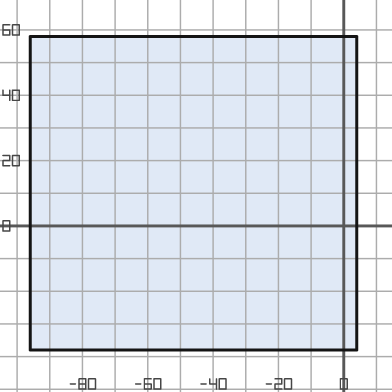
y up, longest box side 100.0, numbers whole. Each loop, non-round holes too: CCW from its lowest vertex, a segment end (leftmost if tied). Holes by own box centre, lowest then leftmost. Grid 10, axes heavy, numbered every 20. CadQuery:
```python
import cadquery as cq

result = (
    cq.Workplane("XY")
    .moveTo(-96.0, -38.0)
    .lineTo(4.0, -38.0)
    .lineTo(4.0, 58.0)
    .lineTo(-96.0, 58.0)
    .close()
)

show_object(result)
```